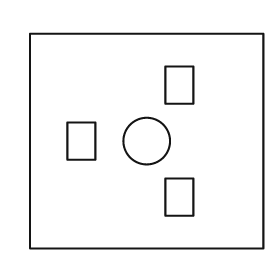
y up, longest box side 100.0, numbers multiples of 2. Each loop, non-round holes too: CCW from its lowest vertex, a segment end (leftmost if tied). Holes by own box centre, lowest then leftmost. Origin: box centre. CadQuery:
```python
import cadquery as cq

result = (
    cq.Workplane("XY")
    .moveTo(-50.0, -46.0)
    .lineTo(50.0, -46.0)
    .lineTo(50.0, 46.0)
    .lineTo(-50.0, 46.0)
    .close()
    .moveTo(8.0, -32.0)
    .lineTo(20.0, -32.0)
    .lineTo(20.0, -16.0)
    .lineTo(8.0, -16.0)
    .close()
    .moveTo(-34.0, -8.0)
    .lineTo(-22.0, -8.0)
    .lineTo(-22.0, 8.0)
    .lineTo(-34.0, 8.0)
    .close()
    .moveTo(0.0, 0.0)
    .circle(10.0)
    .moveTo(8.0, 16.0)
    .lineTo(20.0, 16.0)
    .lineTo(20.0, 32.0)
    .lineTo(8.0, 32.0)
    .close()
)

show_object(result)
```